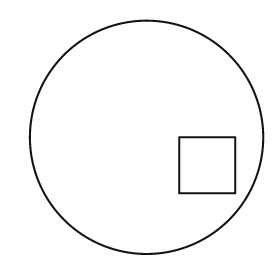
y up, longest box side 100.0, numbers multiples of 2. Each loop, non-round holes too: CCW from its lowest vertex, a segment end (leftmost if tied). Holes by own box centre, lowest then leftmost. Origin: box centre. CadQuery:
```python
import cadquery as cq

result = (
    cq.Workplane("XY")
    .moveTo(0.0, 0.0)
    .circle(50.0)
    .moveTo(14.0, -24.0)
    .lineTo(38.0, -24.0)
    .lineTo(38.0, 0.0)
    .lineTo(14.0, 0.0)
    .close()
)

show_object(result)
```